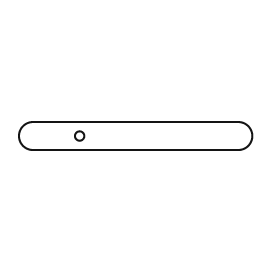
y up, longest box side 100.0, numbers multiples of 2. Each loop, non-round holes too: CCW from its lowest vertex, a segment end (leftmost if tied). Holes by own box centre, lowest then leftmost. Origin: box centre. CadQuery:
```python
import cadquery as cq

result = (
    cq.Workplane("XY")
    .moveTo(-44.0, -6.0)
    .lineTo(44.0, -6.0)
    .threePointArc((50.0, 0.0), (44.0, 6.0))
    .lineTo(-44.0, 6.0)
    .threePointArc((-50.0, 0.0), (-44.0, -6.0))
    .close()
    .moveTo(-24.0, 0.0)
    .circle(2.0)
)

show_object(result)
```